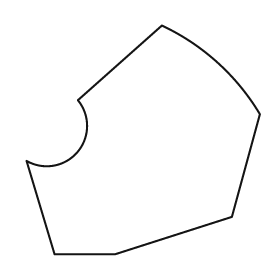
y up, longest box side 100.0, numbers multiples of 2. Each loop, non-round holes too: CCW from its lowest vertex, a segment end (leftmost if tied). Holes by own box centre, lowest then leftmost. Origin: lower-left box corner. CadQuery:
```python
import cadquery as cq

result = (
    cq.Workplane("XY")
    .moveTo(12.0, 0.0)
    .lineTo(38.0, 0.0)
    .lineTo(88.0, 16.0)
    .lineTo(100.0, 60.0)
    .threePointArc((82.0, 82.0), (58.0, 98.0))
    .lineTo(22.0, 66.0)
    .threePointArc((22.0, 44.0), (0.0, 40.0))
    .close()
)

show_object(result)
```